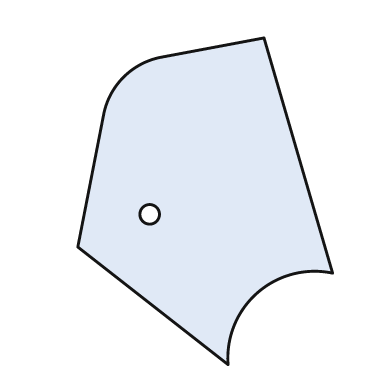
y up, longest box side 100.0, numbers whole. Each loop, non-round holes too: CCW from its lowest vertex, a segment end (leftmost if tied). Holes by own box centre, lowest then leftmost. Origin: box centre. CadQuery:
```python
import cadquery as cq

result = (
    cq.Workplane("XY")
    .moveTo(7.0, -50.0)
    .threePointArc((16.0, -28.0), (39.0, -22.0))
    .lineTo(18.0, 50.0)
    .lineTo(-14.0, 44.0)
    .threePointArc((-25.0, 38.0), (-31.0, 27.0))
    .lineTo(-39.0, -14.0)
    .close()
    .moveTo(-17.0, -4.0)
    .circle(3.0)
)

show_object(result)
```